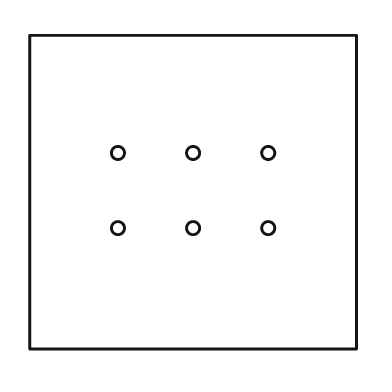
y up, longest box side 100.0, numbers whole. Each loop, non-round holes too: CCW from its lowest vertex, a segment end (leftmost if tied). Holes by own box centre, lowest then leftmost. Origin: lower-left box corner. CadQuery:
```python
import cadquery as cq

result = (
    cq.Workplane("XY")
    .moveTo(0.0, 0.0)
    .lineTo(100.0, 0.0)
    .lineTo(100.0, 96.0)
    .lineTo(0.0, 96.0)
    .close()
    .moveTo(27.0, 37.0)
    .circle(2.0)
    .moveTo(50.0, 37.0)
    .circle(2.0)
    .moveTo(73.0, 37.0)
    .circle(2.0)
    .moveTo(27.0, 60.0)
    .circle(2.0)
    .moveTo(50.0, 60.0)
    .circle(2.0)
    .moveTo(73.0, 60.0)
    .circle(2.0)
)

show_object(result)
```